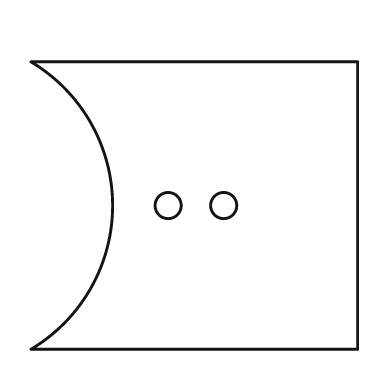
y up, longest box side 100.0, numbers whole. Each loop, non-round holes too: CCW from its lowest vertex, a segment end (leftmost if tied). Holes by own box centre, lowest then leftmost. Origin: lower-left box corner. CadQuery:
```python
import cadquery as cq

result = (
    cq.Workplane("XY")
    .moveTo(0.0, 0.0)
    .lineTo(100.0, 0.0)
    .lineTo(100.0, 88.0)
    .lineTo(0.0, 88.0)
    .threePointArc((25.0, 44.0), (0.0, 0.0))
    .close()
    .moveTo(42.0, 44.0)
    .circle(4.0)
    .moveTo(59.0, 44.0)
    .circle(4.0)
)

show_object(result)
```